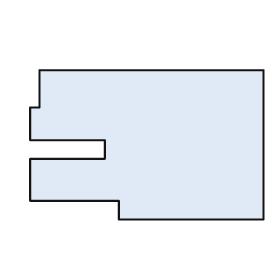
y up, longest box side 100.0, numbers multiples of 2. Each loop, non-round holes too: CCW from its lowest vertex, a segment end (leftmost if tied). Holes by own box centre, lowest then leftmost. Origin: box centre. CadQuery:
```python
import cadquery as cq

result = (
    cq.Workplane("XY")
    .moveTo(-12.0, -32.0)
    .lineTo(50.0, -32.0)
    .lineTo(50.0, 32.0)
    .lineTo(-46.0, 32.0)
    .lineTo(-46.0, 16.0)
    .lineTo(-50.0, 16.0)
    .lineTo(-50.0, 2.0)
    .lineTo(-18.0, 2.0)
    .lineTo(-18.0, -6.0)
    .lineTo(-50.0, -6.0)
    .lineTo(-50.0, -24.0)
    .lineTo(-12.0, -24.0)
    .close()
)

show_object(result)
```